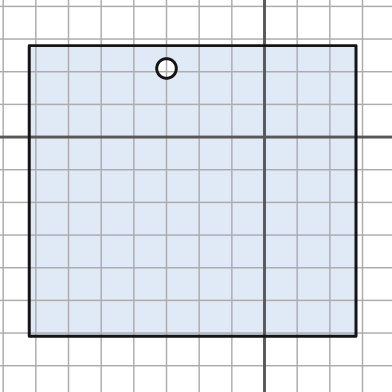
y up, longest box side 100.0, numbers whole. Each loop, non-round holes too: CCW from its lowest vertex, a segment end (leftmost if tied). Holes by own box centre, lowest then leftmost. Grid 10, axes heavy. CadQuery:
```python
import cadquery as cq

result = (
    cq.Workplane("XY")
    .moveTo(-72.0, -61.0)
    .lineTo(28.0, -61.0)
    .lineTo(28.0, 28.0)
    .lineTo(-72.0, 28.0)
    .close()
    .moveTo(-30.0, 21.0)
    .circle(3.0)
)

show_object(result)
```